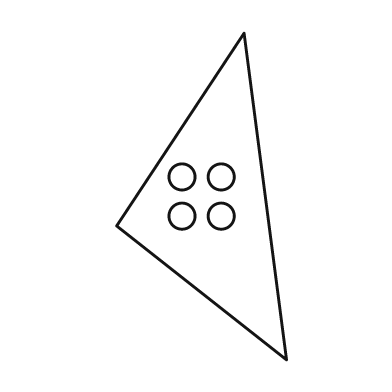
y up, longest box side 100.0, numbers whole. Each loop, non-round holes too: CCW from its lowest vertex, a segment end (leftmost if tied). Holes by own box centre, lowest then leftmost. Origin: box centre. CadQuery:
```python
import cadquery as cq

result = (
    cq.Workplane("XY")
    .moveTo(26.0, -50.0)
    .lineTo(13.0, 50.0)
    .lineTo(-26.0, -9.0)
    .close()
    .moveTo(-6.0, -6.0)
    .circle(4.0)
    .moveTo(6.0, -6.0)
    .circle(4.0)
    .moveTo(-6.0, 6.0)
    .circle(4.0)
    .moveTo(6.0, 6.0)
    .circle(4.0)
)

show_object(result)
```